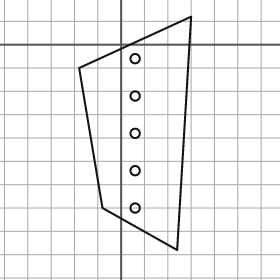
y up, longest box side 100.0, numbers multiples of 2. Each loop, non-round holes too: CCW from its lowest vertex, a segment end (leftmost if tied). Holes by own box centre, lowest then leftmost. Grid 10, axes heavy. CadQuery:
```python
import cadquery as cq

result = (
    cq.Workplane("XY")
    .moveTo(24.0, -88.0)
    .lineTo(30.0, 12.0)
    .lineTo(-18.0, -10.0)
    .lineTo(-8.0, -70.0)
    .close()
    .moveTo(6.0, -70.0)
    .circle(2.0)
    .moveTo(6.0, -54.0)
    .circle(2.0)
    .moveTo(6.0, -38.0)
    .circle(2.0)
    .moveTo(6.0, -22.0)
    .circle(2.0)
    .moveTo(6.0, -6.0)
    .circle(2.0)
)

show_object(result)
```